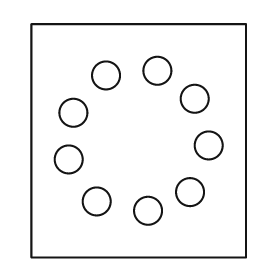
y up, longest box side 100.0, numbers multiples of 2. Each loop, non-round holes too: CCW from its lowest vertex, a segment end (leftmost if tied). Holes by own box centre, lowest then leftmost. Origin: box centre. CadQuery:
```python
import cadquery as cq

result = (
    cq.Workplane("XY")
    .moveTo(-46.0, -50.0)
    .lineTo(46.0, -50.0)
    .lineTo(46.0, 50.0)
    .lineTo(-46.0, 50.0)
    .close()
    .moveTo(4.0, -30.0)
    .circle(6.0)
    .moveTo(-18.0, -26.0)
    .circle(6.0)
    .moveTo(22.0, -22.0)
    .circle(6.0)
    .moveTo(-30.0, -8.0)
    .circle(6.0)
    .moveTo(30.0, -2.0)
    .circle(6.0)
    .moveTo(-28.0, 12.0)
    .circle(6.0)
    .moveTo(24.0, 18.0)
    .circle(6.0)
    .moveTo(-14.0, 28.0)
    .circle(6.0)
    .moveTo(8.0, 30.0)
    .circle(6.0)
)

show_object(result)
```